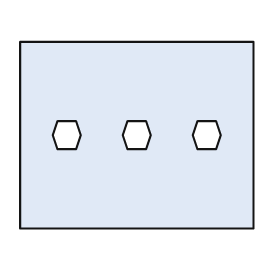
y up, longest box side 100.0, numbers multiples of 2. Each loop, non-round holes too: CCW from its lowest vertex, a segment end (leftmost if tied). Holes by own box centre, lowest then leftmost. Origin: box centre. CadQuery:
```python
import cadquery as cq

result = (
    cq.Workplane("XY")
    .moveTo(-50.0, -40.0)
    .lineTo(50.0, -40.0)
    .lineTo(50.0, 40.0)
    .lineTo(-50.0, 40.0)
    .close()
    .moveTo(-34.0, -6.0)
    .lineTo(-26.0, -6.0)
    .lineTo(-24.0, 0.0)
    .lineTo(-26.0, 6.0)
    .lineTo(-34.0, 6.0)
    .lineTo(-36.0, 0.0)
    .close()
    .moveTo(-4.0, -6.0)
    .lineTo(4.0, -6.0)
    .lineTo(6.0, 0.0)
    .lineTo(4.0, 6.0)
    .lineTo(-4.0, 6.0)
    .lineTo(-6.0, 0.0)
    .close()
    .moveTo(26.0, -6.0)
    .lineTo(34.0, -6.0)
    .lineTo(36.0, 0.0)
    .lineTo(34.0, 6.0)
    .lineTo(26.0, 6.0)
    .lineTo(24.0, 0.0)
    .close()
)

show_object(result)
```